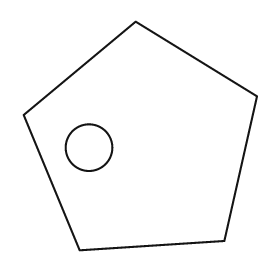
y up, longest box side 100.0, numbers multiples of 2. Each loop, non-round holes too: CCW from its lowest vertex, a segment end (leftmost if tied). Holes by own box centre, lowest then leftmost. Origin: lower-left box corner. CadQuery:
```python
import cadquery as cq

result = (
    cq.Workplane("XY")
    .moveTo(24.0, 0.0)
    .lineTo(86.0, 4.0)
    .lineTo(100.0, 66.0)
    .lineTo(48.0, 98.0)
    .lineTo(0.0, 58.0)
    .close()
    .moveTo(28.0, 44.0)
    .circle(10.0)
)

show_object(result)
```